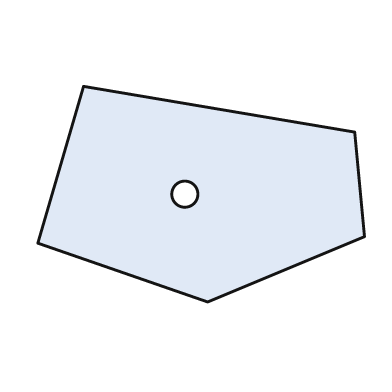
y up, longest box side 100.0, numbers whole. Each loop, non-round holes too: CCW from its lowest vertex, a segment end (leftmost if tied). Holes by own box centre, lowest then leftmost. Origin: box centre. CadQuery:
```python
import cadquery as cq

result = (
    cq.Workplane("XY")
    .moveTo(2.0, -33.0)
    .lineTo(50.0, -13.0)
    .lineTo(47.0, 19.0)
    .lineTo(-36.0, 33.0)
    .lineTo(-50.0, -15.0)
    .close()
    .moveTo(-5.0, 0.0)
    .circle(4.0)
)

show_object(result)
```